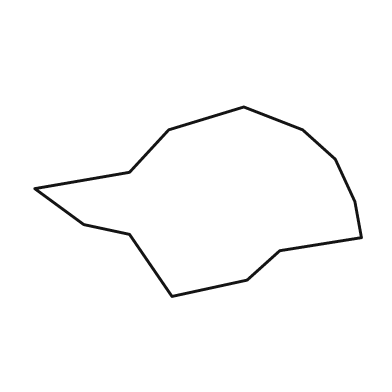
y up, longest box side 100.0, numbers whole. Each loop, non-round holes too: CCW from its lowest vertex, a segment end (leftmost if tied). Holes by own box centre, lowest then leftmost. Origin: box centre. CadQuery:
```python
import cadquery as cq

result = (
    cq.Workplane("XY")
    .moveTo(-8.0, -29.0)
    .lineTo(15.0, -24.0)
    .lineTo(25.0, -15.0)
    .lineTo(50.0, -11.0)
    .lineTo(48.0, 0.0)
    .lineTo(42.0, 13.0)
    .lineTo(32.0, 22.0)
    .lineTo(14.0, 29.0)
    .lineTo(-9.0, 22.0)
    .lineTo(-21.0, 9.0)
    .lineTo(-50.0, 4.0)
    .lineTo(-35.0, -7.0)
    .lineTo(-21.0, -10.0)
    .close()
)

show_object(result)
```